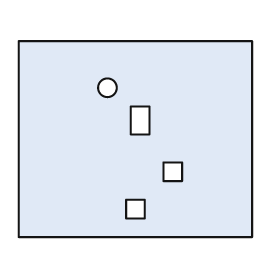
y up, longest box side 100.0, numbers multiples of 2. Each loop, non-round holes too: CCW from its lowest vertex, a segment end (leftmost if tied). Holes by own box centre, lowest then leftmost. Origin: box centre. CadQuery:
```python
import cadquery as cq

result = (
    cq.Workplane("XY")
    .moveTo(-50.0, -42.0)
    .lineTo(50.0, -42.0)
    .lineTo(50.0, 42.0)
    .lineTo(-50.0, 42.0)
    .close()
    .moveTo(-4.0, -34.0)
    .lineTo(4.0, -34.0)
    .lineTo(4.0, -26.0)
    .lineTo(-4.0, -26.0)
    .close()
    .moveTo(12.0, -18.0)
    .lineTo(20.0, -18.0)
    .lineTo(20.0, -10.0)
    .lineTo(12.0, -10.0)
    .close()
    .moveTo(-2.0, 2.0)
    .lineTo(6.0, 2.0)
    .lineTo(6.0, 14.0)
    .lineTo(-2.0, 14.0)
    .close()
    .moveTo(-12.0, 22.0)
    .circle(4.0)
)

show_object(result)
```